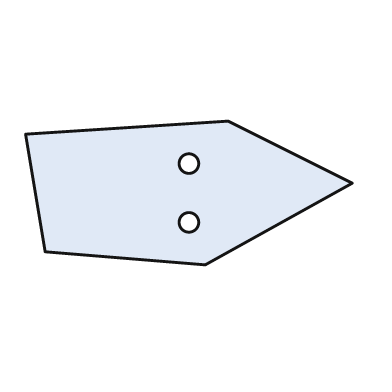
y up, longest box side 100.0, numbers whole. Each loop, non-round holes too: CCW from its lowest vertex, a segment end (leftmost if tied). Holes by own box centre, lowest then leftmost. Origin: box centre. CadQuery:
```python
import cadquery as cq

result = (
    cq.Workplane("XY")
    .moveTo(5.0, -22.0)
    .lineTo(50.0, 3.0)
    .lineTo(12.0, 22.0)
    .lineTo(-50.0, 18.0)
    .lineTo(-44.0, -18.0)
    .close()
    .moveTo(0.0, -9.0)
    .circle(3.0)
    .moveTo(0.0, 9.0)
    .circle(3.0)
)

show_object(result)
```